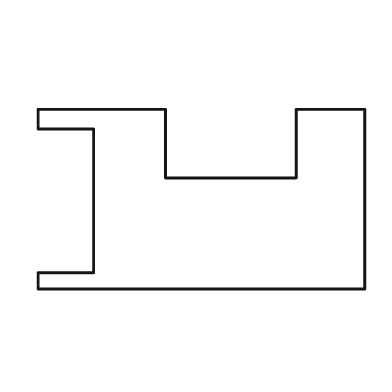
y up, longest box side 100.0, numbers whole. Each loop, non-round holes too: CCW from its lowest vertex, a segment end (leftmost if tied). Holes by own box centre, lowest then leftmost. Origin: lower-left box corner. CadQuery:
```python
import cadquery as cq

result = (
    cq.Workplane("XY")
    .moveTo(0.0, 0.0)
    .lineTo(100.0, 0.0)
    .lineTo(100.0, 55.0)
    .lineTo(79.0, 55.0)
    .lineTo(79.0, 34.0)
    .lineTo(39.0, 34.0)
    .lineTo(39.0, 55.0)
    .lineTo(0.0, 55.0)
    .lineTo(0.0, 49.0)
    .lineTo(17.0, 49.0)
    .lineTo(17.0, 5.0)
    .lineTo(0.0, 5.0)
    .close()
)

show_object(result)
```